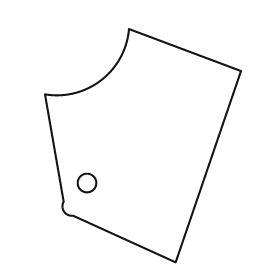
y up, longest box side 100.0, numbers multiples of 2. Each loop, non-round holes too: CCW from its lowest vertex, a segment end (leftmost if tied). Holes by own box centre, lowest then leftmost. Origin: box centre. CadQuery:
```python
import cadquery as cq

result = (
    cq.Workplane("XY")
    .moveTo(14.0, -50.0)
    .lineTo(42.0, 32.0)
    .lineTo(-6.0, 50.0)
    .threePointArc((-18.0, 28.0), (-42.0, 22.0))
    .lineTo(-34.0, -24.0)
    .threePointArc((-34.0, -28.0), (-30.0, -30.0))
    .close()
    .moveTo(-24.0, -16.0)
    .circle(4.0)
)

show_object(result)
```